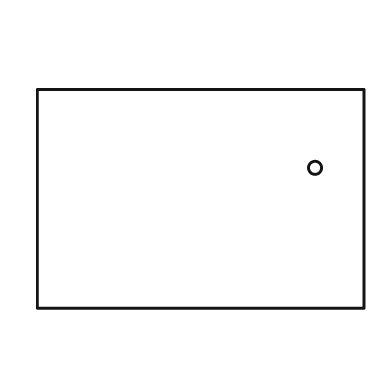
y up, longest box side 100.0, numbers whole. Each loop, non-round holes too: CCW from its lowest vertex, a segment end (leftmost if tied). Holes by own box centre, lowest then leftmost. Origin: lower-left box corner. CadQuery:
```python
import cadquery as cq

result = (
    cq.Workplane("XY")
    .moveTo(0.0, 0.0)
    .lineTo(100.0, 0.0)
    .lineTo(100.0, 67.0)
    .lineTo(0.0, 67.0)
    .close()
    .moveTo(85.0, 43.0)
    .circle(2.0)
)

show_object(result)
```